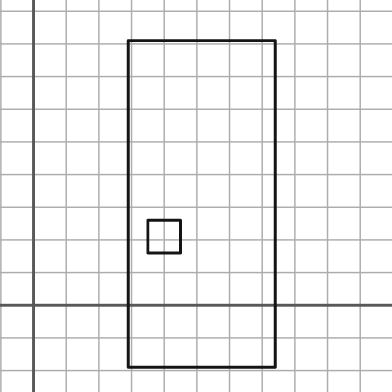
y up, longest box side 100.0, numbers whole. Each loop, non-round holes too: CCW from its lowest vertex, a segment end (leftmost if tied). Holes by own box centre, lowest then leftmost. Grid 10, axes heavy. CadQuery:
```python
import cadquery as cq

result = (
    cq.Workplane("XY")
    .moveTo(29.0, -19.0)
    .lineTo(74.0, -19.0)
    .lineTo(74.0, 81.0)
    .lineTo(29.0, 81.0)
    .close()
    .moveTo(35.0, 16.0)
    .lineTo(45.0, 16.0)
    .lineTo(45.0, 26.0)
    .lineTo(35.0, 26.0)
    .close()
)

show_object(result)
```